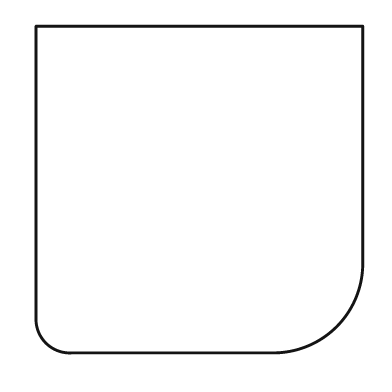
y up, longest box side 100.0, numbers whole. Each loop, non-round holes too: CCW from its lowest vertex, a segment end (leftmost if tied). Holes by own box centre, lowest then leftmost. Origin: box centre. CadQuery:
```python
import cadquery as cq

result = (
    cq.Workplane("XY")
    .moveTo(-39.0, -50.0)
    .lineTo(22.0, -50.0)
    .threePointArc((42.0, -42.0), (50.0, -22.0))
    .lineTo(50.0, 50.0)
    .lineTo(-50.0, 50.0)
    .lineTo(-50.0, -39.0)
    .threePointArc((-47.0, -47.0), (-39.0, -50.0))
    .close()
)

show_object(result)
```